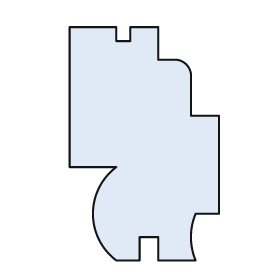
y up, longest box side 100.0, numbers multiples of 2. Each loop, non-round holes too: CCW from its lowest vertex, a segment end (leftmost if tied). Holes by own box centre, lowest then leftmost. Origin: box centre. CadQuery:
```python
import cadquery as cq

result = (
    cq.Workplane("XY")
    .moveTo(-12.0, -50.0)
    .lineTo(-2.0, -50.0)
    .lineTo(-2.0, -40.0)
    .lineTo(6.0, -40.0)
    .lineTo(6.0, -50.0)
    .lineTo(22.0, -50.0)
    .threePointArc((20.0, -40.0), (22.0, -30.0))
    .lineTo(32.0, -30.0)
    .lineTo(32.0, 12.0)
    .lineTo(20.0, 12.0)
    .lineTo(20.0, 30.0)
    .threePointArc((18.0, 34.0), (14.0, 36.0))
    .lineTo(6.0, 36.0)
    .lineTo(6.0, 50.0)
    .lineTo(-6.0, 50.0)
    .lineTo(-6.0, 44.0)
    .lineTo(-12.0, 44.0)
    .lineTo(-12.0, 50.0)
    .lineTo(-32.0, 50.0)
    .lineTo(-32.0, -10.0)
    .lineTo(-12.0, -10.0)
    .threePointArc((-22.0, -30.0), (-12.0, -50.0))
    .close()
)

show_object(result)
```